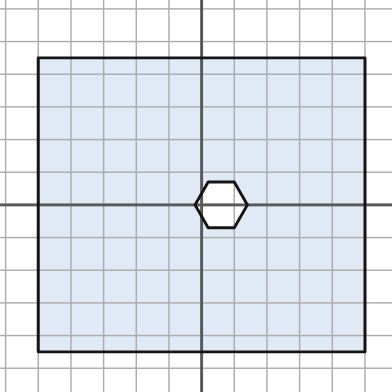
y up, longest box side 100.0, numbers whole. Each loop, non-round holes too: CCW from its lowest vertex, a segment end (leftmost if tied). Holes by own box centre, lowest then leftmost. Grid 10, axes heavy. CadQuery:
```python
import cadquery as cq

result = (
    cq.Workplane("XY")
    .moveTo(-50.0, -45.0)
    .lineTo(50.0, -45.0)
    .lineTo(50.0, 45.0)
    .lineTo(-50.0, 45.0)
    .close()
    .moveTo(2.0, -7.0)
    .lineTo(10.0, -7.0)
    .lineTo(14.0, 0.0)
    .lineTo(10.0, 7.0)
    .lineTo(2.0, 7.0)
    .lineTo(-2.0, 0.0)
    .close()
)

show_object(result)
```